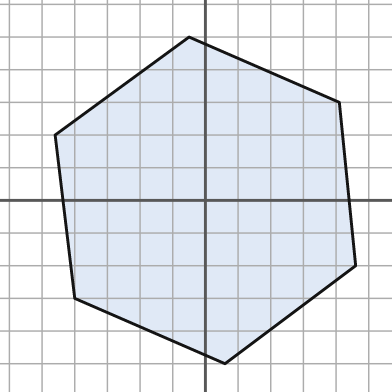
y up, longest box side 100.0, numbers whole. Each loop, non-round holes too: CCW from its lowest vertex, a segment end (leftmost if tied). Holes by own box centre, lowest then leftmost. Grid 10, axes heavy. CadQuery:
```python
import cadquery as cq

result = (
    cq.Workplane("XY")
    .moveTo(6.0, -50.0)
    .lineTo(46.0, -20.0)
    .lineTo(41.0, 30.0)
    .lineTo(-5.0, 50.0)
    .lineTo(-46.0, 20.0)
    .lineTo(-40.0, -30.0)
    .close()
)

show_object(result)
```